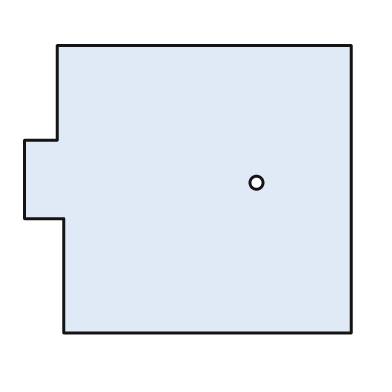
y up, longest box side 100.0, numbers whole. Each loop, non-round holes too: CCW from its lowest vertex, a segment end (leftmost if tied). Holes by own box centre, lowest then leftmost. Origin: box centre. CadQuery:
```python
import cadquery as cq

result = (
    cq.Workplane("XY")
    .moveTo(-38.0, -44.0)
    .lineTo(50.0, -44.0)
    .lineTo(50.0, 44.0)
    .lineTo(-40.0, 44.0)
    .lineTo(-40.0, 15.0)
    .lineTo(-50.0, 15.0)
    .lineTo(-50.0, -9.0)
    .lineTo(-38.0, -9.0)
    .close()
    .moveTo(21.0, 2.0)
    .circle(2.0)
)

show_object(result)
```